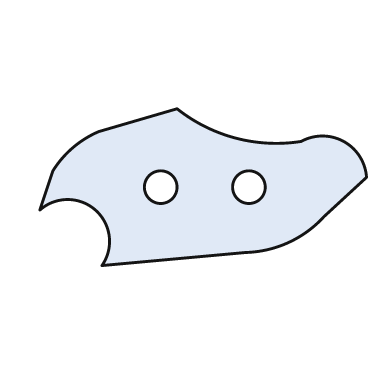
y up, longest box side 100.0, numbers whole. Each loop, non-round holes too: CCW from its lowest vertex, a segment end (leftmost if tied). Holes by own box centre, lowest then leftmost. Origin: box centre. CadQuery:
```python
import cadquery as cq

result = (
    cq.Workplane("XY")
    .moveTo(-31.0, -24.0)
    .lineTo(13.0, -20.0)
    .threePointArc((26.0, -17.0), (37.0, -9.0))
    .lineTo(50.0, 3.0)
    .threePointArc((43.0, 14.0), (30.0, 14.0))
    .threePointArc((10.0, 15.0), (-8.0, 24.0))
    .lineTo(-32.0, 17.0)
    .threePointArc((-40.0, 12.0), (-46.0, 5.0))
    .lineTo(-50.0, -7.0)
    .threePointArc((-33.0, -7.0), (-31.0, -24.0))
    .close()
    .moveTo(-13.0, 0.0)
    .circle(5.0)
    .moveTo(14.0, 0.0)
    .circle(5.0)
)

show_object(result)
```